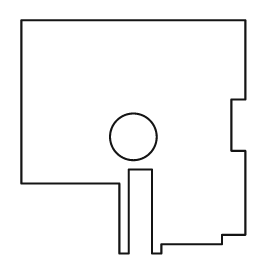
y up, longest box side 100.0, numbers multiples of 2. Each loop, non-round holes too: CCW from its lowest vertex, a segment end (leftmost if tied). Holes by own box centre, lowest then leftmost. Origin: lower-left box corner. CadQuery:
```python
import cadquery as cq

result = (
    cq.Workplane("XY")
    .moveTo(42.0, 0.0)
    .lineTo(46.0, 0.0)
    .lineTo(46.0, 36.0)
    .lineTo(56.0, 36.0)
    .lineTo(56.0, 0.0)
    .lineTo(60.0, 0.0)
    .lineTo(60.0, 4.0)
    .lineTo(86.0, 4.0)
    .lineTo(86.0, 8.0)
    .lineTo(96.0, 8.0)
    .lineTo(96.0, 44.0)
    .lineTo(90.0, 44.0)
    .lineTo(90.0, 66.0)
    .lineTo(96.0, 66.0)
    .lineTo(96.0, 100.0)
    .lineTo(0.0, 100.0)
    .lineTo(0.0, 30.0)
    .lineTo(42.0, 30.0)
    .close()
    .moveTo(48.0, 50.0)
    .circle(10.0)
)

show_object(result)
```